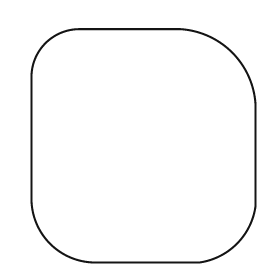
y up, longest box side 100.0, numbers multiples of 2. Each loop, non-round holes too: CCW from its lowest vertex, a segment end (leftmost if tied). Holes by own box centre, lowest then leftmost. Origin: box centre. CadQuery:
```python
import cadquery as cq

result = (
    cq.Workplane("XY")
    .moveTo(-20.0, -50.0)
    .lineTo(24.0, -50.0)
    .threePointArc((40.0, -42.0), (48.0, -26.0))
    .lineTo(48.0, 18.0)
    .threePointArc((38.0, 40.0), (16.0, 50.0))
    .lineTo(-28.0, 50.0)
    .threePointArc((-42.0, 44.0), (-48.0, 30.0))
    .lineTo(-48.0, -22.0)
    .threePointArc((-40.0, -42.0), (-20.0, -50.0))
    .close()
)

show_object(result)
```